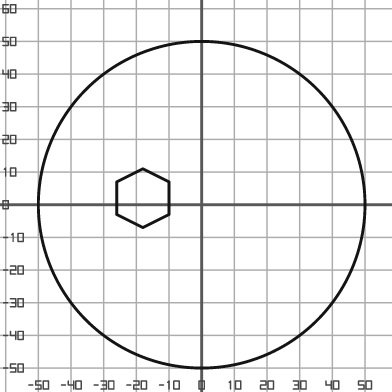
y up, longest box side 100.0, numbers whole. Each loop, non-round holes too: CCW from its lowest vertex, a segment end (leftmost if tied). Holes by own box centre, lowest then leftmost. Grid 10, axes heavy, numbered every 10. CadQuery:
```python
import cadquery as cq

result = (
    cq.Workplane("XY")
    .moveTo(0.0, 0.0)
    .circle(50.0)
    .moveTo(-18.0, -7.0)
    .lineTo(-10.0, -3.0)
    .lineTo(-10.0, 7.0)
    .lineTo(-18.0, 11.0)
    .lineTo(-26.0, 7.0)
    .lineTo(-26.0, -3.0)
    .close()
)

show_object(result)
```